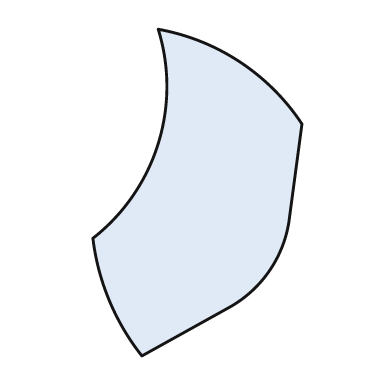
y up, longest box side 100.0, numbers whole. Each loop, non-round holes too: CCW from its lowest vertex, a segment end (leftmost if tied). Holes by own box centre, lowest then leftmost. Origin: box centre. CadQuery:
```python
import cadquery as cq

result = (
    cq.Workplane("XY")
    .moveTo(-17.0, -50.0)
    .lineTo(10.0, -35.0)
    .threePointArc((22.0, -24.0), (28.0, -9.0))
    .lineTo(32.0, 21.0)
    .threePointArc((13.0, 40.0), (-12.0, 50.0))
    .threePointArc((-12.0, 15.0), (-32.0, -14.0))
    .threePointArc((-27.0, -33.0), (-17.0, -50.0))
    .close()
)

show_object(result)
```